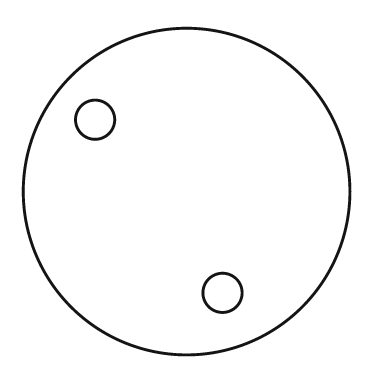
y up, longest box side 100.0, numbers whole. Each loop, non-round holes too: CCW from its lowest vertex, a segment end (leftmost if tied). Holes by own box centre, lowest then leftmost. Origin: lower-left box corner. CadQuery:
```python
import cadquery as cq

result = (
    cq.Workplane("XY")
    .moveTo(50.0, 50.0)
    .circle(50.0)
    .moveTo(61.0, 19.0)
    .circle(6.0)
    .moveTo(22.0, 72.0)
    .circle(6.0)
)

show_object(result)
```